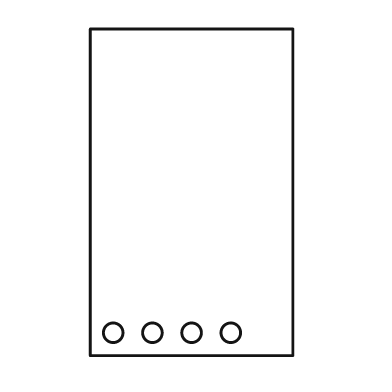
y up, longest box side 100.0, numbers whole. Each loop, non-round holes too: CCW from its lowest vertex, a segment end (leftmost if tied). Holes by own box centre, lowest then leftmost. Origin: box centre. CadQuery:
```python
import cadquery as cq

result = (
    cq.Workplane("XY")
    .moveTo(-31.0, -50.0)
    .lineTo(31.0, -50.0)
    .lineTo(31.0, 50.0)
    .lineTo(-31.0, 50.0)
    .close()
    .moveTo(-24.0, -43.0)
    .circle(3.0)
    .moveTo(-12.0, -43.0)
    .circle(3.0)
    .moveTo(0.0, -43.0)
    .circle(3.0)
    .moveTo(12.0, -43.0)
    .circle(3.0)
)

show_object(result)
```